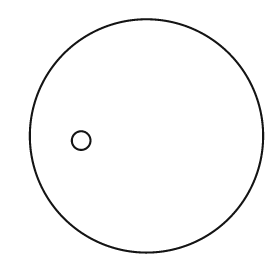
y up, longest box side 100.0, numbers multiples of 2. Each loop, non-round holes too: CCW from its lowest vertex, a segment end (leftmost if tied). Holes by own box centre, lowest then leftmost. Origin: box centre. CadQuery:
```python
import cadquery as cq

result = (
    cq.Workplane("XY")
    .moveTo(0.0, 0.0)
    .circle(50.0)
    .moveTo(-28.0, -2.0)
    .circle(4.0)
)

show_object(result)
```